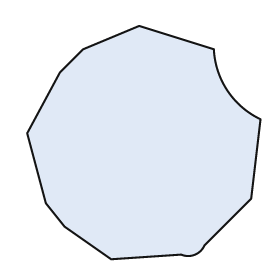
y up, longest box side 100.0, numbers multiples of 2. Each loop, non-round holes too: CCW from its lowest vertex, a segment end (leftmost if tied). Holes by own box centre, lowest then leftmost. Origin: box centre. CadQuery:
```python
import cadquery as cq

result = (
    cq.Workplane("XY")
    .moveTo(-14.0, -50.0)
    .lineTo(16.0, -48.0)
    .threePointArc((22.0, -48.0), (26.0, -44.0))
    .lineTo(46.0, -24.0)
    .lineTo(50.0, 10.0)
    .threePointArc((36.0, 22.0), (30.0, 40.0))
    .lineTo(-2.0, 50.0)
    .lineTo(-26.0, 40.0)
    .lineTo(-36.0, 30.0)
    .lineTo(-50.0, 4.0)
    .lineTo(-42.0, -26.0)
    .lineTo(-34.0, -36.0)
    .close()
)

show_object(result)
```